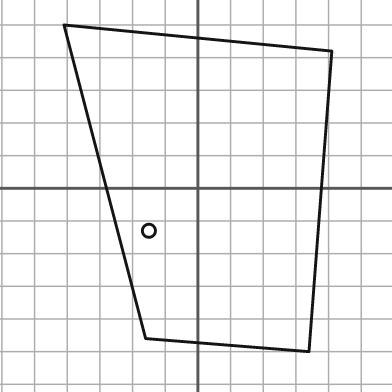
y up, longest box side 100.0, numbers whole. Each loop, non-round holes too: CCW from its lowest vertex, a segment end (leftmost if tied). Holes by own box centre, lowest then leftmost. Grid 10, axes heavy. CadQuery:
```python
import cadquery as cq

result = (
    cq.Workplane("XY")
    .moveTo(34.0, -50.0)
    .lineTo(41.0, 42.0)
    .lineTo(-41.0, 50.0)
    .lineTo(-16.0, -46.0)
    .close()
    .moveTo(-15.0, -13.0)
    .circle(2.0)
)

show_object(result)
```